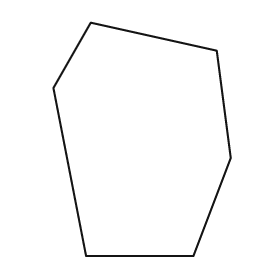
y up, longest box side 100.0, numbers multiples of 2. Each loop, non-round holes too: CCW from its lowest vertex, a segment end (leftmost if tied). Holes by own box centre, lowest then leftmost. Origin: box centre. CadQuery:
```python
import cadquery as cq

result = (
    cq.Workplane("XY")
    .moveTo(-24.0, -50.0)
    .lineTo(22.0, -50.0)
    .lineTo(38.0, -8.0)
    .lineTo(32.0, 38.0)
    .lineTo(-22.0, 50.0)
    .lineTo(-38.0, 22.0)
    .close()
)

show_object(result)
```